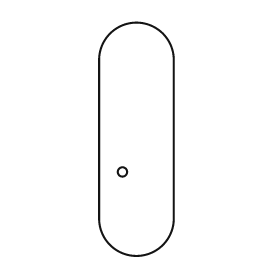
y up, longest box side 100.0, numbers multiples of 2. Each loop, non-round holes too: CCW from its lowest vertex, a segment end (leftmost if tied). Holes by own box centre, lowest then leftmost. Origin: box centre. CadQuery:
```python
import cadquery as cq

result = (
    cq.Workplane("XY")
    .moveTo(-16.0, -34.0)
    .threePointArc((0.0, -50.0), (16.0, -34.0))
    .lineTo(16.0, 34.0)
    .threePointArc((0.0, 50.0), (-16.0, 34.0))
    .close()
    .moveTo(-6.0, -14.0)
    .circle(2.0)
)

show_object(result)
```